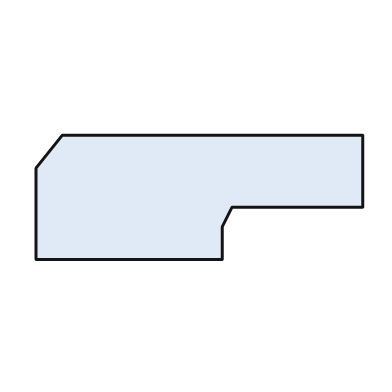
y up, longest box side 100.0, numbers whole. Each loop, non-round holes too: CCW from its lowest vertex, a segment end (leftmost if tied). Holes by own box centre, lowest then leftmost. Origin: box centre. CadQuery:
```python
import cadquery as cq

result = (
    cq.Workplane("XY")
    .moveTo(-50.0, -19.0)
    .lineTo(7.0, -19.0)
    .lineTo(7.0, -9.0)
    .lineTo(10.0, -3.0)
    .lineTo(50.0, -3.0)
    .lineTo(50.0, 19.0)
    .lineTo(-42.0, 19.0)
    .lineTo(-50.0, 9.0)
    .close()
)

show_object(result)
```